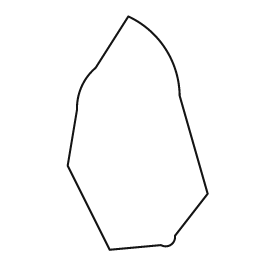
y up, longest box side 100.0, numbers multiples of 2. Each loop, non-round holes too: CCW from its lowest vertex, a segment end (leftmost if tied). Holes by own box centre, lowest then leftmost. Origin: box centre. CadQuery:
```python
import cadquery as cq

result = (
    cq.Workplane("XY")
    .moveTo(-12.0, -50.0)
    .lineTo(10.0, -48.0)
    .threePointArc((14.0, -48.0), (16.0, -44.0))
    .lineTo(30.0, -26.0)
    .lineTo(18.0, 16.0)
    .threePointArc((12.0, 36.0), (-4.0, 50.0))
    .lineTo(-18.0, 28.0)
    .threePointArc((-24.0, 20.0), (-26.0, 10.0))
    .lineTo(-30.0, -14.0)
    .close()
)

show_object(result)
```